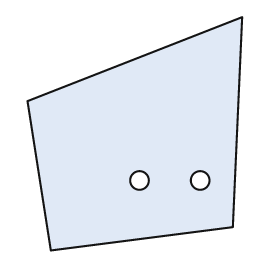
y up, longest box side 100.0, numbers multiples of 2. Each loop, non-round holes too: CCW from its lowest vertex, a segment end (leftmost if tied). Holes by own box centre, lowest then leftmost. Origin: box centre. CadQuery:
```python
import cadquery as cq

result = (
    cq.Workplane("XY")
    .moveTo(-36.0, -50.0)
    .lineTo(42.0, -40.0)
    .lineTo(46.0, 50.0)
    .lineTo(-46.0, 14.0)
    .close()
    .moveTo(2.0, -20.0)
    .circle(4.0)
    .moveTo(28.0, -20.0)
    .circle(4.0)
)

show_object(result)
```